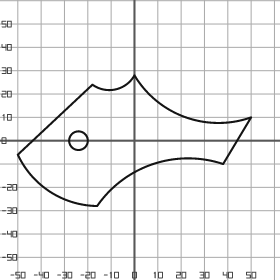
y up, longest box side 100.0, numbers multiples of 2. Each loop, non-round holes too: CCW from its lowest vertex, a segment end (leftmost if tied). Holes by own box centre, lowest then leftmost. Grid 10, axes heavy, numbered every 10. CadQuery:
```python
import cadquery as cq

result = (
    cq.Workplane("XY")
    .moveTo(-16.0, -28.0)
    .threePointArc((8.0, -10.0), (38.0, -10.0))
    .lineTo(50.0, 10.0)
    .threePointArc((22.0, 10.0), (0.0, 28.0))
    .threePointArc((-8.0, 22.0), (-18.0, 24.0))
    .lineTo(-50.0, -6.0)
    .threePointArc((-36.0, -22.0), (-16.0, -28.0))
    .close()
    .moveTo(-24.0, 0.0)
    .circle(4.0)
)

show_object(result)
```